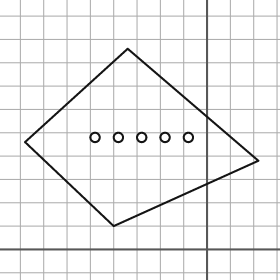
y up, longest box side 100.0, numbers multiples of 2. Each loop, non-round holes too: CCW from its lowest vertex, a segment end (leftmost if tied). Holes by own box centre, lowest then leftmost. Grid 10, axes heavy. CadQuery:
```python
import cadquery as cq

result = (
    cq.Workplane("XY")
    .moveTo(-40.0, 10.0)
    .lineTo(22.0, 38.0)
    .lineTo(-34.0, 86.0)
    .lineTo(-78.0, 46.0)
    .close()
    .moveTo(-48.0, 48.0)
    .circle(2.0)
    .moveTo(-38.0, 48.0)
    .circle(2.0)
    .moveTo(-28.0, 48.0)
    .circle(2.0)
    .moveTo(-18.0, 48.0)
    .circle(2.0)
    .moveTo(-8.0, 48.0)
    .circle(2.0)
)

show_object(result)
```